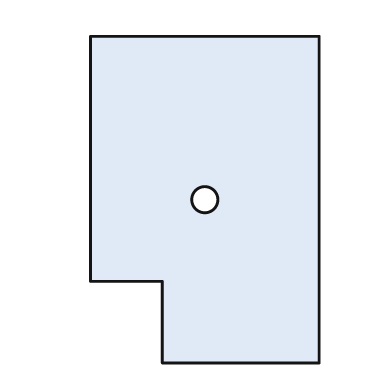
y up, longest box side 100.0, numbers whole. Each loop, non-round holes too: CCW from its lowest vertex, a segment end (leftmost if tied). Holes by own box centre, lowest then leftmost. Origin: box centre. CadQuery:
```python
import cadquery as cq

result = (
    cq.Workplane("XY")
    .moveTo(-13.0, -50.0)
    .lineTo(35.0, -50.0)
    .lineTo(35.0, 50.0)
    .lineTo(-35.0, 50.0)
    .lineTo(-35.0, -25.0)
    .lineTo(-13.0, -25.0)
    .close()
    .moveTo(0.0, 0.0)
    .circle(4.0)
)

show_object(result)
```